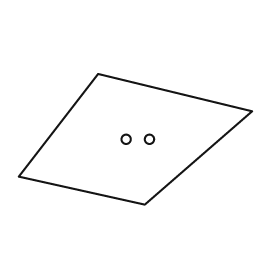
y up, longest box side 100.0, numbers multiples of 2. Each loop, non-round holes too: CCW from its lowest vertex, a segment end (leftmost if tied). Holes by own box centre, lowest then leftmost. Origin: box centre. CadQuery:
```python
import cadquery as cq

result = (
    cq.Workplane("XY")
    .moveTo(4.0, -28.0)
    .lineTo(50.0, 12.0)
    .lineTo(-16.0, 28.0)
    .lineTo(-50.0, -16.0)
    .close()
    .moveTo(-4.0, 0.0)
    .circle(2.0)
    .moveTo(6.0, 0.0)
    .circle(2.0)
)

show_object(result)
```